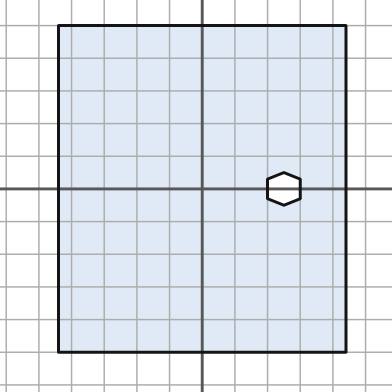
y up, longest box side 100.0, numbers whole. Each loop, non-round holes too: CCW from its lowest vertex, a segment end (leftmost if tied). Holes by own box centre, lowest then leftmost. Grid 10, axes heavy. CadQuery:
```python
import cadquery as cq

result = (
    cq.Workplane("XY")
    .moveTo(-44.0, -50.0)
    .lineTo(44.0, -50.0)
    .lineTo(44.0, 50.0)
    .lineTo(-44.0, 50.0)
    .close()
    .moveTo(25.0, -5.0)
    .lineTo(30.0, -3.0)
    .lineTo(30.0, 3.0)
    .lineTo(25.0, 5.0)
    .lineTo(20.0, 3.0)
    .lineTo(20.0, -3.0)
    .close()
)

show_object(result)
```